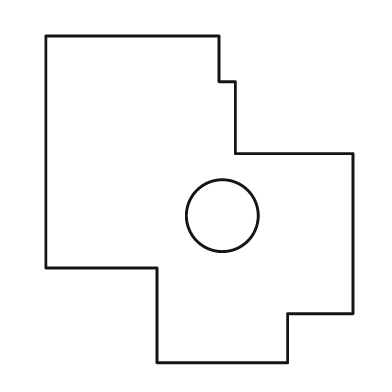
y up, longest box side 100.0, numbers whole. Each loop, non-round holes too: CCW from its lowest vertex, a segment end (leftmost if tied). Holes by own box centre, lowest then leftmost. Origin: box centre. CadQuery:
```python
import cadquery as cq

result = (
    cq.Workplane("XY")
    .moveTo(-13.0, -50.0)
    .lineTo(27.0, -50.0)
    .lineTo(27.0, -35.0)
    .lineTo(47.0, -35.0)
    .lineTo(47.0, 14.0)
    .lineTo(11.0, 14.0)
    .lineTo(11.0, 36.0)
    .lineTo(6.0, 36.0)
    .lineTo(6.0, 50.0)
    .lineTo(-47.0, 50.0)
    .lineTo(-47.0, -21.0)
    .lineTo(-13.0, -21.0)
    .close()
    .moveTo(7.0, -5.0)
    .circle(11.0)
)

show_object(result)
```